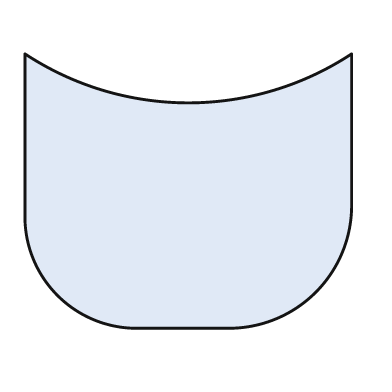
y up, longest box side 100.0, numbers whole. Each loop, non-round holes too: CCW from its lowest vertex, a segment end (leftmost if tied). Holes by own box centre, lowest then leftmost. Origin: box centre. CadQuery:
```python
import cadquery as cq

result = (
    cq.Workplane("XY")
    .moveTo(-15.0, -42.0)
    .lineTo(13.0, -42.0)
    .threePointArc((39.0, -31.0), (50.0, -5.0))
    .lineTo(50.0, 42.0)
    .threePointArc((0.0, 27.0), (-50.0, 42.0))
    .lineTo(-50.0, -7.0)
    .threePointArc((-40.0, -32.0), (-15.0, -42.0))
    .close()
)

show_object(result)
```